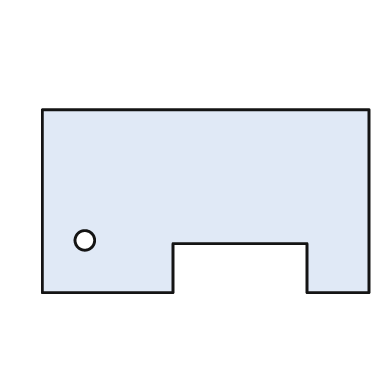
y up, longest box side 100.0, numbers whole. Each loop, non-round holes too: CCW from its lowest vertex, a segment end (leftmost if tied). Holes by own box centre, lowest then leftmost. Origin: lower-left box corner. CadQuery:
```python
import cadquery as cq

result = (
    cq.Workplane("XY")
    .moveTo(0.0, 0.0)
    .lineTo(40.0, 0.0)
    .lineTo(40.0, 15.0)
    .lineTo(81.0, 15.0)
    .lineTo(81.0, 0.0)
    .lineTo(100.0, 0.0)
    .lineTo(100.0, 56.0)
    .lineTo(0.0, 56.0)
    .close()
    .moveTo(13.0, 16.0)
    .circle(3.0)
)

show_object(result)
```